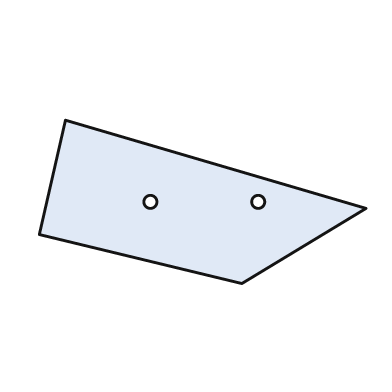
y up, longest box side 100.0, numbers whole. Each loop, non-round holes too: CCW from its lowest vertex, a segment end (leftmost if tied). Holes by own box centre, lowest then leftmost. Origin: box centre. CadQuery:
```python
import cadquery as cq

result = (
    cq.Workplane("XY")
    .moveTo(12.0, -25.0)
    .lineTo(50.0, -2.0)
    .lineTo(-42.0, 25.0)
    .lineTo(-50.0, -10.0)
    .close()
    .moveTo(-16.0, 0.0)
    .circle(2.0)
    .moveTo(17.0, 0.0)
    .circle(2.0)
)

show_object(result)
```